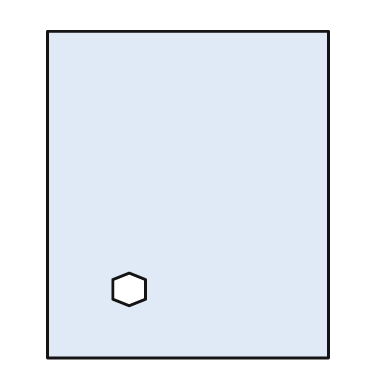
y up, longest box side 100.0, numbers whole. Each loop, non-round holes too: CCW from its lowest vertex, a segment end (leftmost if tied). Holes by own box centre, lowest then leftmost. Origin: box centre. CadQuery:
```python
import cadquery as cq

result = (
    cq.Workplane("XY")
    .moveTo(-43.0, -50.0)
    .lineTo(43.0, -50.0)
    .lineTo(43.0, 50.0)
    .lineTo(-43.0, 50.0)
    .close()
    .moveTo(-18.0, -34.0)
    .lineTo(-13.0, -32.0)
    .lineTo(-13.0, -26.0)
    .lineTo(-18.0, -24.0)
    .lineTo(-23.0, -26.0)
    .lineTo(-23.0, -32.0)
    .close()
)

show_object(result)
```